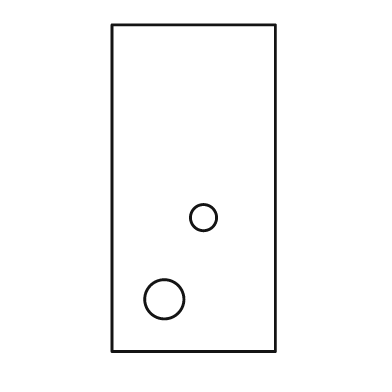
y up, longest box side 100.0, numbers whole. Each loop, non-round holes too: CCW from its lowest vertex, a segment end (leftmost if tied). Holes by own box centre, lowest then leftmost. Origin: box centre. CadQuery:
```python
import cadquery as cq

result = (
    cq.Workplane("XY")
    .moveTo(-25.0, -50.0)
    .lineTo(25.0, -50.0)
    .lineTo(25.0, 50.0)
    .lineTo(-25.0, 50.0)
    .close()
    .moveTo(-9.0, -34.0)
    .circle(6.0)
    .moveTo(3.0, -9.0)
    .circle(4.0)
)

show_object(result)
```